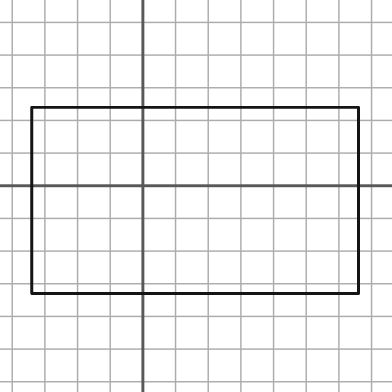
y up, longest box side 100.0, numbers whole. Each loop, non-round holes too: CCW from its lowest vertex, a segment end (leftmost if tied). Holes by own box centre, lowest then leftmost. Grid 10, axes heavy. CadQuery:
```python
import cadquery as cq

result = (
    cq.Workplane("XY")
    .moveTo(-34.0, -33.0)
    .lineTo(66.0, -33.0)
    .lineTo(66.0, 24.0)
    .lineTo(-34.0, 24.0)
    .close()
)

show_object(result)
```